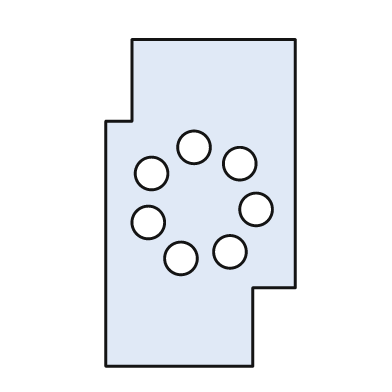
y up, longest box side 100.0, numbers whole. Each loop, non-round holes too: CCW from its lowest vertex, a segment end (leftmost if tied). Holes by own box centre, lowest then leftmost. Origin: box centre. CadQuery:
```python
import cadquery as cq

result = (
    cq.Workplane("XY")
    .moveTo(-29.0, -50.0)
    .lineTo(16.0, -50.0)
    .lineTo(16.0, -26.0)
    .lineTo(29.0, -26.0)
    .lineTo(29.0, 50.0)
    .lineTo(-21.0, 50.0)
    .lineTo(-21.0, 25.0)
    .lineTo(-29.0, 25.0)
    .close()
    .moveTo(-6.0, -17.0)
    .circle(5.0)
    .moveTo(9.0, -15.0)
    .circle(5.0)
    .moveTo(-16.0, -6.0)
    .circle(5.0)
    .moveTo(17.0, -2.0)
    .circle(5.0)
    .moveTo(-15.0, 9.0)
    .circle(5.0)
    .moveTo(12.0, 12.0)
    .circle(5.0)
    .moveTo(-2.0, 17.0)
    .circle(5.0)
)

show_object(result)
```